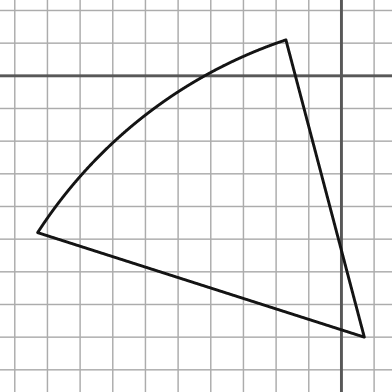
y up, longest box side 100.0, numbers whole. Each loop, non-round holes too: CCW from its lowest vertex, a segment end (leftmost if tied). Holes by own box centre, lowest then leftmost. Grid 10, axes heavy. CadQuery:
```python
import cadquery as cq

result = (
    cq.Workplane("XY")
    .moveTo(7.0, -80.0)
    .lineTo(-17.0, 11.0)
    .threePointArc((-60.0, -12.0), (-93.0, -48.0))
    .close()
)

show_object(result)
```